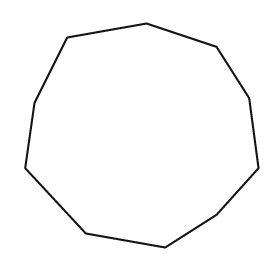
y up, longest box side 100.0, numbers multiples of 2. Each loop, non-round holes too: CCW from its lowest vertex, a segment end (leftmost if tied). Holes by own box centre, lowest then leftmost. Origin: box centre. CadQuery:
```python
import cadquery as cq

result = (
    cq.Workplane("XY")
    .moveTo(10.0, -48.0)
    .lineTo(32.0, -34.0)
    .lineTo(50.0, -14.0)
    .lineTo(46.0, 16.0)
    .lineTo(32.0, 38.0)
    .lineTo(2.0, 48.0)
    .lineTo(-32.0, 42.0)
    .lineTo(-46.0, 14.0)
    .lineTo(-50.0, -14.0)
    .lineTo(-24.0, -42.0)
    .close()
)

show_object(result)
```